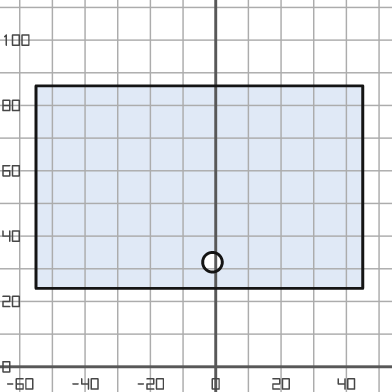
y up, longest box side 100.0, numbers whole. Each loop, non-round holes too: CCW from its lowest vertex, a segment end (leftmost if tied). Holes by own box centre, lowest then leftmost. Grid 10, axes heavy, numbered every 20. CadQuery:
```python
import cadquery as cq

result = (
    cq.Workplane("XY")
    .moveTo(-55.0, 24.0)
    .lineTo(45.0, 24.0)
    .lineTo(45.0, 86.0)
    .lineTo(-55.0, 86.0)
    .close()
    .moveTo(-1.0, 32.0)
    .circle(3.0)
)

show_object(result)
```